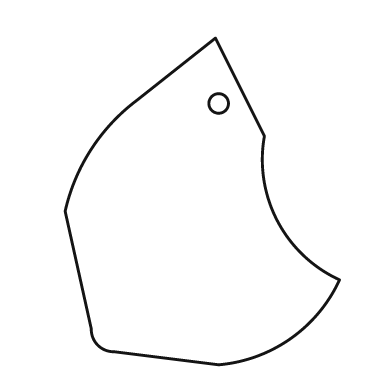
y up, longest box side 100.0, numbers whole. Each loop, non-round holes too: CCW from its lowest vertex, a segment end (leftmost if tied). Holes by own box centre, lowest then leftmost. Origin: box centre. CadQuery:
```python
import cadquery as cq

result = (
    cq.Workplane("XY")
    .moveTo(5.0, -50.0)
    .threePointArc((27.0, -42.0), (42.0, -24.0))
    .threePointArc((23.0, -6.0), (19.0, 20.0))
    .lineTo(4.0, 50.0)
    .lineTo(-20.0, 31.0)
    .threePointArc((-34.0, 16.0), (-42.0, -3.0))
    .lineTo(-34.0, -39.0)
    .threePointArc((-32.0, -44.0), (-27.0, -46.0))
    .close()
    .moveTo(5.0, 30.0)
    .circle(3.0)
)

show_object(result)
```